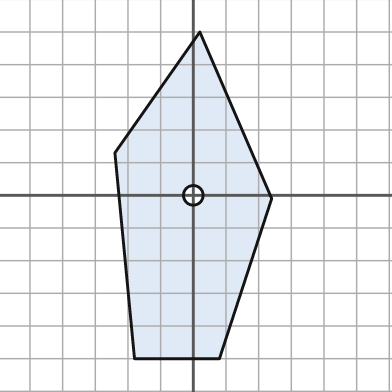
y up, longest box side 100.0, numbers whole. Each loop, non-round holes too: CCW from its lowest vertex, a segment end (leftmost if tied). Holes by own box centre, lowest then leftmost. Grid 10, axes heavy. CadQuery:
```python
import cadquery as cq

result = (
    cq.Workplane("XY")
    .moveTo(-18.0, -50.0)
    .lineTo(8.0, -50.0)
    .lineTo(24.0, -1.0)
    .lineTo(2.0, 50.0)
    .lineTo(-24.0, 13.0)
    .close()
    .moveTo(0.0, 0.0)
    .circle(3.0)
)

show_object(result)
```